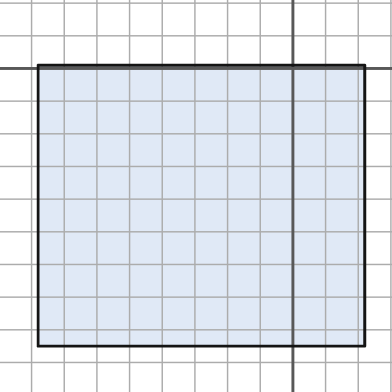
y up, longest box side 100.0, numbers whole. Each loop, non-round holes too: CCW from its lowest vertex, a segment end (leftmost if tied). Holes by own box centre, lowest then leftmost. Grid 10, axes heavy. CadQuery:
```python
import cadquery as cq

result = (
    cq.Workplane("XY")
    .moveTo(-78.0, -85.0)
    .lineTo(22.0, -85.0)
    .lineTo(22.0, 1.0)
    .lineTo(-78.0, 1.0)
    .close()
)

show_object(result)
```